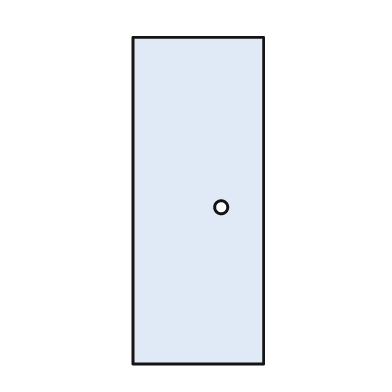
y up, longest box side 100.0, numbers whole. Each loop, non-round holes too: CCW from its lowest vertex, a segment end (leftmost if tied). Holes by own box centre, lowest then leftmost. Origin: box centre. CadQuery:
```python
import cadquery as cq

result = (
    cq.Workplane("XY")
    .moveTo(-20.0, -50.0)
    .lineTo(20.0, -50.0)
    .lineTo(20.0, 50.0)
    .lineTo(-20.0, 50.0)
    .close()
    .moveTo(7.0, -2.0)
    .circle(2.0)
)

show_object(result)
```